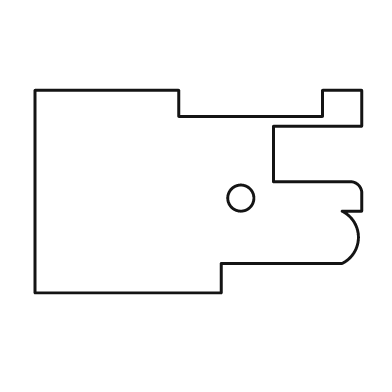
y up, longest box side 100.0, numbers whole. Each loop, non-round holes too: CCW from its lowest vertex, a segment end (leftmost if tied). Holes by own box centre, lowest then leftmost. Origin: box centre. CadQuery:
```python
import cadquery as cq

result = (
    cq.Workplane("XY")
    .moveTo(-50.0, -31.0)
    .lineTo(7.0, -31.0)
    .lineTo(7.0, -22.0)
    .lineTo(44.0, -22.0)
    .threePointArc((49.0, -14.0), (44.0, -6.0))
    .lineTo(50.0, -6.0)
    .lineTo(50.0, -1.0)
    .threePointArc((49.0, 2.0), (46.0, 3.0))
    .lineTo(23.0, 3.0)
    .lineTo(23.0, 20.0)
    .lineTo(50.0, 20.0)
    .lineTo(50.0, 31.0)
    .lineTo(38.0, 31.0)
    .lineTo(38.0, 23.0)
    .lineTo(-6.0, 23.0)
    .lineTo(-6.0, 31.0)
    .lineTo(-50.0, 31.0)
    .close()
    .moveTo(13.0, -2.0)
    .circle(4.0)
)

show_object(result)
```